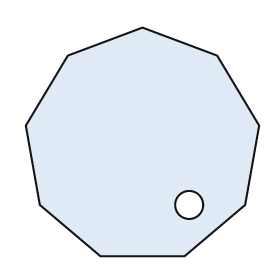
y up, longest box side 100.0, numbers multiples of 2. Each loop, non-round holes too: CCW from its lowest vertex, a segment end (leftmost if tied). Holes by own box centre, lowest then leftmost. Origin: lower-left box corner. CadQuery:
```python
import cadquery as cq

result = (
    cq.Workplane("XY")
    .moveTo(32.0, 0.0)
    .lineTo(68.0, 0.0)
    .lineTo(94.0, 22.0)
    .lineTo(100.0, 56.0)
    .lineTo(82.0, 86.0)
    .lineTo(50.0, 98.0)
    .lineTo(18.0, 86.0)
    .lineTo(0.0, 56.0)
    .lineTo(6.0, 22.0)
    .close()
    .moveTo(70.0, 22.0)
    .circle(6.0)
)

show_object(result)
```